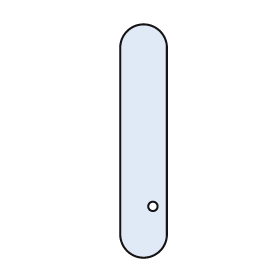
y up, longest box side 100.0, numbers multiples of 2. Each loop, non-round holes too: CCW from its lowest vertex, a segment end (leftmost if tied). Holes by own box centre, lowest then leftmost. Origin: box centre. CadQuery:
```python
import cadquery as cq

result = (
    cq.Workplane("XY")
    .moveTo(-10.0, -40.0)
    .threePointArc((0.0, -50.0), (10.0, -40.0))
    .lineTo(10.0, 40.0)
    .threePointArc((0.0, 50.0), (-10.0, 40.0))
    .close()
    .moveTo(4.0, -28.0)
    .circle(2.0)
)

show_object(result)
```